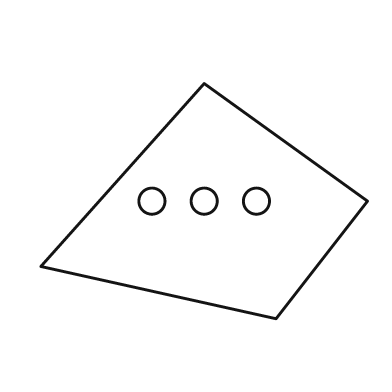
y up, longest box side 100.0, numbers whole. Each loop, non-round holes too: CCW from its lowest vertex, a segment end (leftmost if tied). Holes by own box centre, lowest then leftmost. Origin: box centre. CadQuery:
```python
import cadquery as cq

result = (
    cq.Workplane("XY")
    .moveTo(22.0, -36.0)
    .lineTo(50.0, 0.0)
    .lineTo(0.0, 36.0)
    .lineTo(-50.0, -20.0)
    .close()
    .moveTo(-16.0, 0.0)
    .circle(4.0)
    .moveTo(0.0, 0.0)
    .circle(4.0)
    .moveTo(16.0, 0.0)
    .circle(4.0)
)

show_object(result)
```